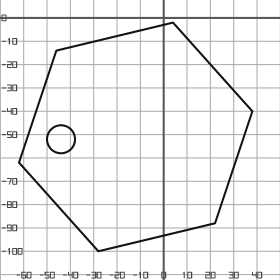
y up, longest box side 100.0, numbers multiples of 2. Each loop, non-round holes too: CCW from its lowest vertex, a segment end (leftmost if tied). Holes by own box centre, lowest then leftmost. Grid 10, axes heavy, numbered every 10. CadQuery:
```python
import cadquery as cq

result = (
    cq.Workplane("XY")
    .moveTo(-28.0, -100.0)
    .lineTo(22.0, -88.0)
    .lineTo(38.0, -40.0)
    .lineTo(4.0, -2.0)
    .lineTo(-46.0, -14.0)
    .lineTo(-62.0, -62.0)
    .close()
    .moveTo(-44.0, -52.0)
    .circle(6.0)
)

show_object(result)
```